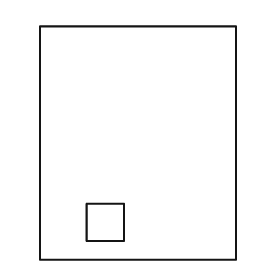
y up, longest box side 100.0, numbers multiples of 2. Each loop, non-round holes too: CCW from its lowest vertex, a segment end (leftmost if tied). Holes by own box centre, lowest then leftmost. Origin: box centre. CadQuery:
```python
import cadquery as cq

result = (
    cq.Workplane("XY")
    .moveTo(-42.0, -50.0)
    .lineTo(42.0, -50.0)
    .lineTo(42.0, 50.0)
    .lineTo(-42.0, 50.0)
    .close()
    .moveTo(-22.0, -42.0)
    .lineTo(-6.0, -42.0)
    .lineTo(-6.0, -26.0)
    .lineTo(-22.0, -26.0)
    .close()
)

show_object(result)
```